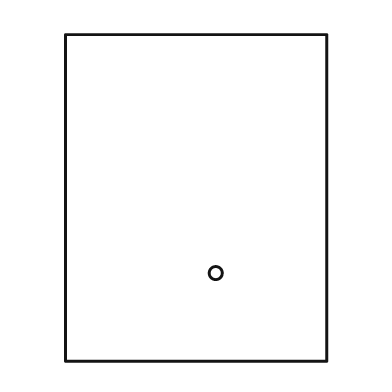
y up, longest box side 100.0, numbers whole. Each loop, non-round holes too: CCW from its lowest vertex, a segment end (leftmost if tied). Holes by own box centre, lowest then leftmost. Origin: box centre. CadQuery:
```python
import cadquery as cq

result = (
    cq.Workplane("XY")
    .moveTo(-40.0, -50.0)
    .lineTo(40.0, -50.0)
    .lineTo(40.0, 50.0)
    .lineTo(-40.0, 50.0)
    .close()
    .moveTo(6.0, -23.0)
    .circle(2.0)
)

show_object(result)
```